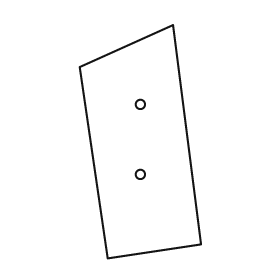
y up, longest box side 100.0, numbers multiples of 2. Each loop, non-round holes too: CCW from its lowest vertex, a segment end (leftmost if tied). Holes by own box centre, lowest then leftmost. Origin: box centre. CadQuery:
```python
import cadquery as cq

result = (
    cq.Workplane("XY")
    .moveTo(-14.0, -50.0)
    .lineTo(26.0, -44.0)
    .lineTo(14.0, 50.0)
    .lineTo(-26.0, 32.0)
    .close()
    .moveTo(0.0, -14.0)
    .circle(2.0)
    .moveTo(0.0, 16.0)
    .circle(2.0)
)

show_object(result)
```